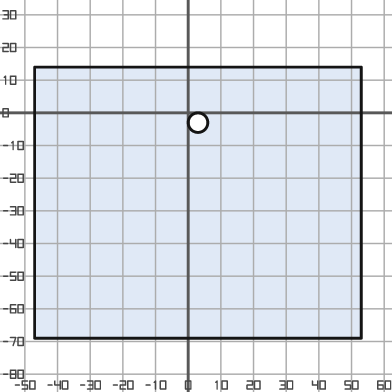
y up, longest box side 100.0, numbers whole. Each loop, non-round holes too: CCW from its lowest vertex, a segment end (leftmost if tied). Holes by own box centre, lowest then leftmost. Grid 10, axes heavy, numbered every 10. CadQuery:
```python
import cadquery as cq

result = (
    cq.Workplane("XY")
    .moveTo(-47.0, -69.0)
    .lineTo(53.0, -69.0)
    .lineTo(53.0, 14.0)
    .lineTo(-47.0, 14.0)
    .close()
    .moveTo(3.0, -3.0)
    .circle(3.0)
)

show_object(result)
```